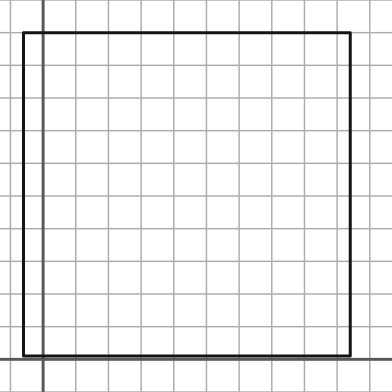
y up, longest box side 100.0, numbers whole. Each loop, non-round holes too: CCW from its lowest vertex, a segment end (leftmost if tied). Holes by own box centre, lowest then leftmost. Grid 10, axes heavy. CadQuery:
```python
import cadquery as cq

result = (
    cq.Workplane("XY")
    .moveTo(-6.0, 1.0)
    .lineTo(94.0, 1.0)
    .lineTo(94.0, 100.0)
    .lineTo(-6.0, 100.0)
    .close()
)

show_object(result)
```